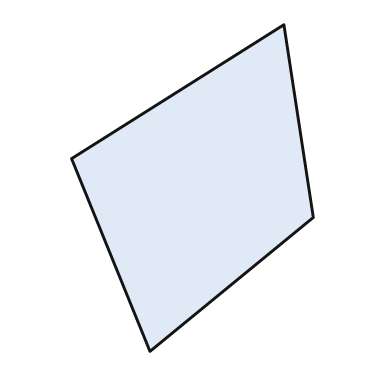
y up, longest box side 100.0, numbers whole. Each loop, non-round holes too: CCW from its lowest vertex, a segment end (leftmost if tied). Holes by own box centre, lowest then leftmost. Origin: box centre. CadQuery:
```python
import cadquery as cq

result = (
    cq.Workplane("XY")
    .moveTo(-13.0, -50.0)
    .lineTo(37.0, -9.0)
    .lineTo(28.0, 50.0)
    .lineTo(-37.0, 9.0)
    .close()
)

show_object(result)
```